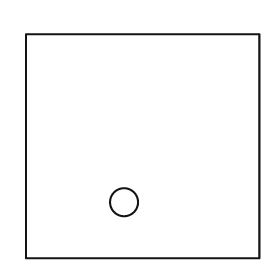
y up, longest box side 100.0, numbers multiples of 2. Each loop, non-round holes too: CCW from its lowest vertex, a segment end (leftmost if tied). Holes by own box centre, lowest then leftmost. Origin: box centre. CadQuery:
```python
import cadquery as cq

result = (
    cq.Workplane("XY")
    .moveTo(-50.0, -48.0)
    .lineTo(50.0, -48.0)
    .lineTo(50.0, 48.0)
    .lineTo(-50.0, 48.0)
    .close()
    .moveTo(-8.0, -24.0)
    .circle(6.0)
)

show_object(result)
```